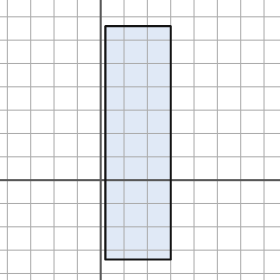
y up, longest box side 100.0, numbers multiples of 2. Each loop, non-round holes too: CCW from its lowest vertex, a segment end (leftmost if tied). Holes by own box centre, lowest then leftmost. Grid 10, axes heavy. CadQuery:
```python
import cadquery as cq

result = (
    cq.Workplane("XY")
    .moveTo(2.0, -34.0)
    .lineTo(30.0, -34.0)
    .lineTo(30.0, 66.0)
    .lineTo(2.0, 66.0)
    .close()
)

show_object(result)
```